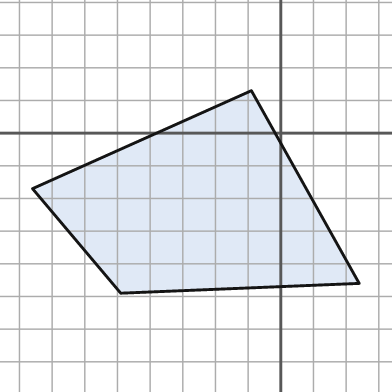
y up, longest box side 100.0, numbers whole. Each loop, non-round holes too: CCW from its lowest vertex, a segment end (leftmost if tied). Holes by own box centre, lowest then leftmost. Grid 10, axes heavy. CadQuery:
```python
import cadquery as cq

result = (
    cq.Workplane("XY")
    .moveTo(-49.0, -49.0)
    .lineTo(24.0, -46.0)
    .lineTo(-9.0, 13.0)
    .lineTo(-76.0, -17.0)
    .close()
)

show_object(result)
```